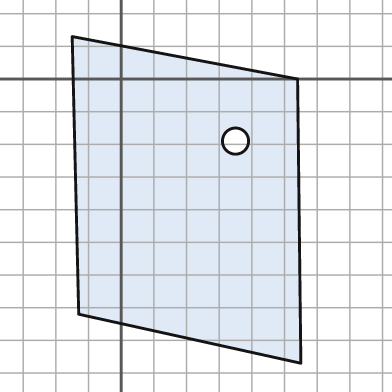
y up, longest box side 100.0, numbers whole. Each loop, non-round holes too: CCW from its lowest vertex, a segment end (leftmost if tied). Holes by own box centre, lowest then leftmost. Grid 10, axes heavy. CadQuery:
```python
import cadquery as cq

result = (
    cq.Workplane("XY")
    .moveTo(55.0, -87.0)
    .lineTo(54.0, 0.0)
    .lineTo(-15.0, 13.0)
    .lineTo(-13.0, -72.0)
    .close()
    .moveTo(35.0, -19.0)
    .circle(4.0)
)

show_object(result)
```